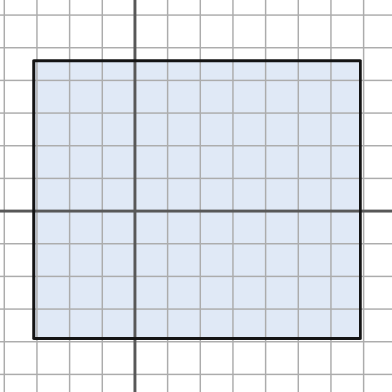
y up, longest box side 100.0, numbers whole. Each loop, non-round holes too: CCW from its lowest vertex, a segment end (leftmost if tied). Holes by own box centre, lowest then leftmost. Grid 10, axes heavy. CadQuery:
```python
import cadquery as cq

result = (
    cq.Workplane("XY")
    .moveTo(-31.0, -39.0)
    .lineTo(69.0, -39.0)
    .lineTo(69.0, 46.0)
    .lineTo(-31.0, 46.0)
    .close()
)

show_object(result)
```